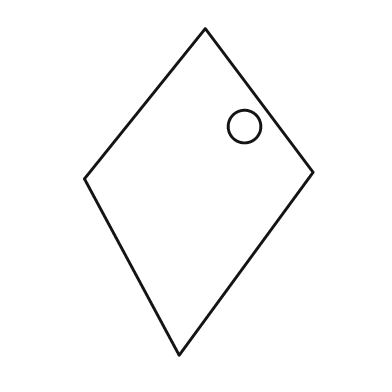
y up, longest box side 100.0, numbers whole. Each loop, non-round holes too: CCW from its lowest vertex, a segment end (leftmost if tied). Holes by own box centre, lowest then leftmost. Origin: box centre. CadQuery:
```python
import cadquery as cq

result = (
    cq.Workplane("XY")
    .moveTo(-6.0, -50.0)
    .lineTo(35.0, 6.0)
    .lineTo(2.0, 50.0)
    .lineTo(-35.0, 4.0)
    .close()
    .moveTo(14.0, 20.0)
    .circle(5.0)
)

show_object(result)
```